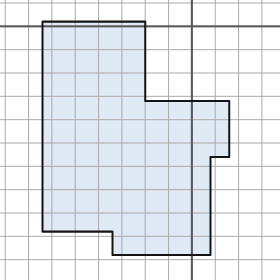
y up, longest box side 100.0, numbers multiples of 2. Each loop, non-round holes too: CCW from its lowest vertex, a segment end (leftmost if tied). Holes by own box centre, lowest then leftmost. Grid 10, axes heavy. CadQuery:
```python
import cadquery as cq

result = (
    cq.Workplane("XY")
    .moveTo(-34.0, -98.0)
    .lineTo(8.0, -98.0)
    .lineTo(8.0, -56.0)
    .lineTo(16.0, -56.0)
    .lineTo(16.0, -32.0)
    .lineTo(-20.0, -32.0)
    .lineTo(-20.0, 2.0)
    .lineTo(-64.0, 2.0)
    .lineTo(-64.0, -88.0)
    .lineTo(-34.0, -88.0)
    .close()
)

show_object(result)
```